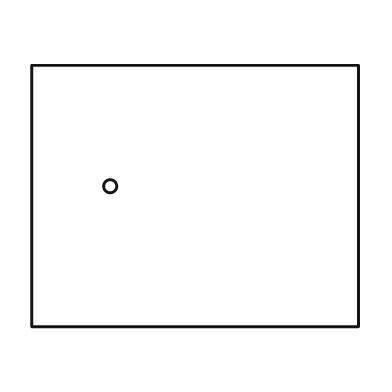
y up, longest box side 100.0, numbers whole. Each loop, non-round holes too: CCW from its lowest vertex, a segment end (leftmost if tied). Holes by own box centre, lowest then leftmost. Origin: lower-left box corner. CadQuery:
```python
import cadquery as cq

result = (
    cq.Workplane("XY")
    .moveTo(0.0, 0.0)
    .lineTo(100.0, 0.0)
    .lineTo(100.0, 80.0)
    .lineTo(0.0, 80.0)
    .close()
    .moveTo(24.0, 43.0)
    .circle(2.0)
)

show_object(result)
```